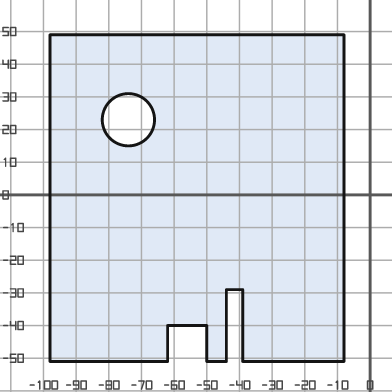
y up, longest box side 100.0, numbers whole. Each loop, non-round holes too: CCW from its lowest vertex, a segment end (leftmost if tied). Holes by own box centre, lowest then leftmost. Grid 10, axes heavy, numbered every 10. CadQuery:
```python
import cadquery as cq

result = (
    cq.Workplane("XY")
    .moveTo(-98.0, -51.0)
    .lineTo(-62.0, -51.0)
    .lineTo(-62.0, -40.0)
    .lineTo(-50.0, -40.0)
    .lineTo(-50.0, -51.0)
    .lineTo(-44.0, -51.0)
    .lineTo(-44.0, -29.0)
    .lineTo(-39.0, -29.0)
    .lineTo(-39.0, -51.0)
    .lineTo(-8.0, -51.0)
    .lineTo(-8.0, 49.0)
    .lineTo(-98.0, 49.0)
    .close()
    .moveTo(-74.0, 23.0)
    .circle(8.0)
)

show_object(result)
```